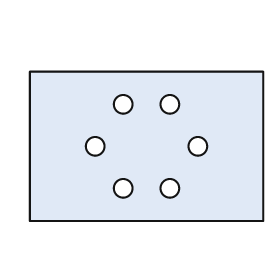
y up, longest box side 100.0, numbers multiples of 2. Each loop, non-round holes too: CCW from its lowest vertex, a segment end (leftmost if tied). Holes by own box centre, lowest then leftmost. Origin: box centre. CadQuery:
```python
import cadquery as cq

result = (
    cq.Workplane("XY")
    .moveTo(-50.0, -32.0)
    .lineTo(50.0, -32.0)
    .lineTo(50.0, 32.0)
    .lineTo(-50.0, 32.0)
    .close()
    .moveTo(-10.0, -18.0)
    .circle(4.0)
    .moveTo(10.0, -18.0)
    .circle(4.0)
    .moveTo(-22.0, 0.0)
    .circle(4.0)
    .moveTo(22.0, 0.0)
    .circle(4.0)
    .moveTo(-10.0, 18.0)
    .circle(4.0)
    .moveTo(10.0, 18.0)
    .circle(4.0)
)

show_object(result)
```